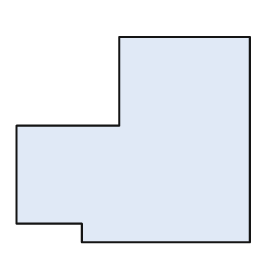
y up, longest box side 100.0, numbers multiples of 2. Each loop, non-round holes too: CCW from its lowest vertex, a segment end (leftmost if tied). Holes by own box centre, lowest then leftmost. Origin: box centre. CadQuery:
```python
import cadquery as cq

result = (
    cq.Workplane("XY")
    .moveTo(-22.0, -44.0)
    .lineTo(50.0, -44.0)
    .lineTo(50.0, 44.0)
    .lineTo(-6.0, 44.0)
    .lineTo(-6.0, 6.0)
    .lineTo(-50.0, 6.0)
    .lineTo(-50.0, -36.0)
    .lineTo(-22.0, -36.0)
    .close()
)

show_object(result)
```